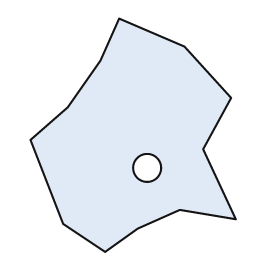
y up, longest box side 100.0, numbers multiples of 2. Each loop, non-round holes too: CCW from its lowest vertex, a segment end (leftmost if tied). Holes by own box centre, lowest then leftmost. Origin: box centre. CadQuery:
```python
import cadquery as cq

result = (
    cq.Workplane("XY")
    .moveTo(-12.0, -50.0)
    .lineTo(2.0, -40.0)
    .lineTo(20.0, -32.0)
    .lineTo(44.0, -36.0)
    .lineTo(30.0, -6.0)
    .lineTo(42.0, 16.0)
    .lineTo(22.0, 38.0)
    .lineTo(-6.0, 50.0)
    .lineTo(-14.0, 32.0)
    .lineTo(-28.0, 12.0)
    .lineTo(-44.0, -2.0)
    .lineTo(-30.0, -38.0)
    .close()
    .moveTo(6.0, -14.0)
    .circle(6.0)
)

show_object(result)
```